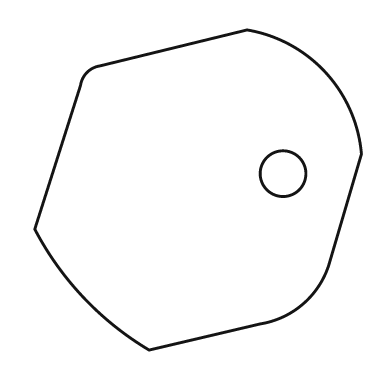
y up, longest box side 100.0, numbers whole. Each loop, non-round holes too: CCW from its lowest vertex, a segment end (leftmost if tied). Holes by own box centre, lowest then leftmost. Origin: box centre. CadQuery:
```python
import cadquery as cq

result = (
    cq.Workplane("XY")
    .moveTo(-15.0, -49.0)
    .lineTo(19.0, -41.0)
    .threePointArc((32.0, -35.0), (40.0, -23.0))
    .lineTo(50.0, 11.0)
    .threePointArc((39.0, 36.0), (15.0, 49.0))
    .lineTo(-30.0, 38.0)
    .threePointArc((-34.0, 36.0), (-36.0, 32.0))
    .lineTo(-50.0, -12.0)
    .threePointArc((-35.0, -33.0), (-15.0, -49.0))
    .close()
    .moveTo(26.0, 5.0)
    .circle(7.0)
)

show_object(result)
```